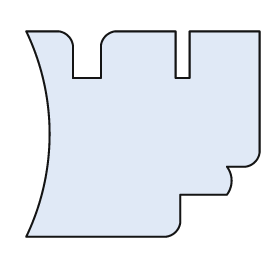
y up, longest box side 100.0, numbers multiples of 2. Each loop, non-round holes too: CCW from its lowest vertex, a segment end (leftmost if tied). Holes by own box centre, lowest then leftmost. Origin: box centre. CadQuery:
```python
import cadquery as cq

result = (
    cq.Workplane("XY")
    .moveTo(-50.0, -44.0)
    .lineTo(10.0, -44.0)
    .threePointArc((14.0, -42.0), (16.0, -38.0))
    .lineTo(16.0, -26.0)
    .lineTo(36.0, -26.0)
    .threePointArc((38.0, -20.0), (36.0, -14.0))
    .lineTo(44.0, -14.0)
    .threePointArc((48.0, -12.0), (50.0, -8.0))
    .lineTo(50.0, 44.0)
    .lineTo(20.0, 44.0)
    .lineTo(20.0, 24.0)
    .lineTo(14.0, 24.0)
    .lineTo(14.0, 44.0)
    .lineTo(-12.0, 44.0)
    .threePointArc((-16.0, 42.0), (-18.0, 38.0))
    .lineTo(-18.0, 24.0)
    .lineTo(-30.0, 24.0)
    .lineTo(-30.0, 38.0)
    .threePointArc((-32.0, 42.0), (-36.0, 44.0))
    .lineTo(-50.0, 44.0)
    .threePointArc((-40.0, 0.0), (-50.0, -44.0))
    .close()
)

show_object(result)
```